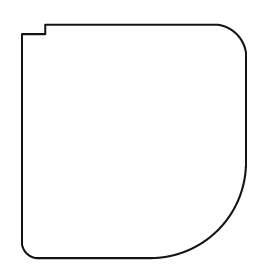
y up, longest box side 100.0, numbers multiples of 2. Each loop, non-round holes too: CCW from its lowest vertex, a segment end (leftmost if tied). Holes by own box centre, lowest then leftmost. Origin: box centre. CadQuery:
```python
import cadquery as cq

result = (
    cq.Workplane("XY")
    .moveTo(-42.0, -50.0)
    .lineTo(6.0, -50.0)
    .threePointArc((36.0, -38.0), (48.0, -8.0))
    .lineTo(48.0, 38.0)
    .threePointArc((44.0, 46.0), (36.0, 50.0))
    .lineTo(-38.0, 50.0)
    .lineTo(-38.0, 46.0)
    .lineTo(-48.0, 46.0)
    .lineTo(-48.0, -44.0)
    .threePointArc((-46.0, -48.0), (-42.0, -50.0))
    .close()
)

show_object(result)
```